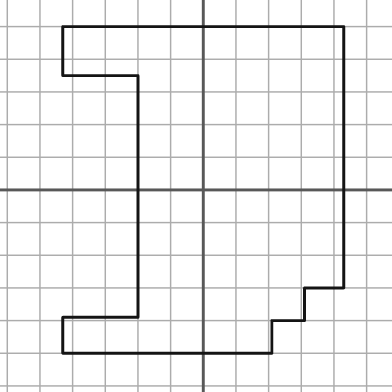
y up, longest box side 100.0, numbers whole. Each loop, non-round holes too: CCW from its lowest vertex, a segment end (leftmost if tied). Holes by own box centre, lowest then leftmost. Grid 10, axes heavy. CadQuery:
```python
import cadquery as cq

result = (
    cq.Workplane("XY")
    .moveTo(-43.0, -50.0)
    .lineTo(21.0, -50.0)
    .lineTo(21.0, -40.0)
    .lineTo(31.0, -40.0)
    .lineTo(31.0, -30.0)
    .lineTo(43.0, -30.0)
    .lineTo(43.0, 50.0)
    .lineTo(-43.0, 50.0)
    .lineTo(-43.0, 35.0)
    .lineTo(-20.0, 35.0)
    .lineTo(-20.0, -39.0)
    .lineTo(-43.0, -39.0)
    .close()
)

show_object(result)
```